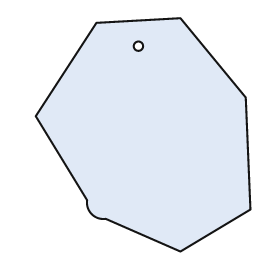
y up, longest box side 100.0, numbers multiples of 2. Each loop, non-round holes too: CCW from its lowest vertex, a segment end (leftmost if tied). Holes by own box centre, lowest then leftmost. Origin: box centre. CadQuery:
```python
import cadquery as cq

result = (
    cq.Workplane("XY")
    .moveTo(16.0, -50.0)
    .lineTo(46.0, -32.0)
    .lineTo(44.0, 16.0)
    .lineTo(16.0, 50.0)
    .lineTo(-20.0, 48.0)
    .lineTo(-46.0, 8.0)
    .lineTo(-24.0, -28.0)
    .threePointArc((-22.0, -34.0), (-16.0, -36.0))
    .close()
    .moveTo(-2.0, 38.0)
    .circle(2.0)
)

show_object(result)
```